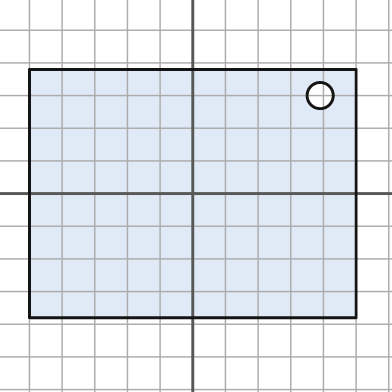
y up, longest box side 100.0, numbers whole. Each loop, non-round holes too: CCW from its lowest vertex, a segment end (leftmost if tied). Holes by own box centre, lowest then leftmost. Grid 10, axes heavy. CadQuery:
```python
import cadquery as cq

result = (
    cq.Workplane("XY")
    .moveTo(-50.0, -38.0)
    .lineTo(50.0, -38.0)
    .lineTo(50.0, 38.0)
    .lineTo(-50.0, 38.0)
    .close()
    .moveTo(39.0, 30.0)
    .circle(4.0)
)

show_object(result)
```